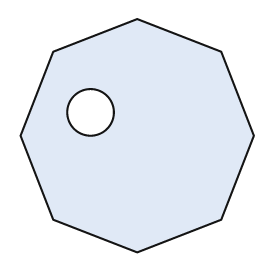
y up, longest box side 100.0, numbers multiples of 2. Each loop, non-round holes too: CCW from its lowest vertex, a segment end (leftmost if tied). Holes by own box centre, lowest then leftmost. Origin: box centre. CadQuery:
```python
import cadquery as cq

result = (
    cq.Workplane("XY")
    .moveTo(0.0, -50.0)
    .lineTo(36.0, -36.0)
    .lineTo(50.0, 0.0)
    .lineTo(36.0, 36.0)
    .lineTo(0.0, 50.0)
    .lineTo(-36.0, 36.0)
    .lineTo(-50.0, 0.0)
    .lineTo(-36.0, -36.0)
    .close()
    .moveTo(-20.0, 10.0)
    .circle(10.0)
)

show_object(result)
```